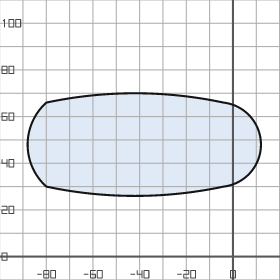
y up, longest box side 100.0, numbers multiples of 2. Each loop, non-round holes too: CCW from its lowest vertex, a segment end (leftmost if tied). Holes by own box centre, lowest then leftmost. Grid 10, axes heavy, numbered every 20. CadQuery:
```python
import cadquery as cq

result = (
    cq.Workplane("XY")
    .moveTo(-80.0, 30.0)
    .threePointArc((-42.0, 26.0), (-4.0, 30.0))
    .threePointArc((12.0, 48.0), (-4.0, 66.0))
    .threePointArc((-42.0, 70.0), (-80.0, 66.0))
    .threePointArc((-88.0, 48.0), (-80.0, 30.0))
    .close()
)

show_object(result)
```